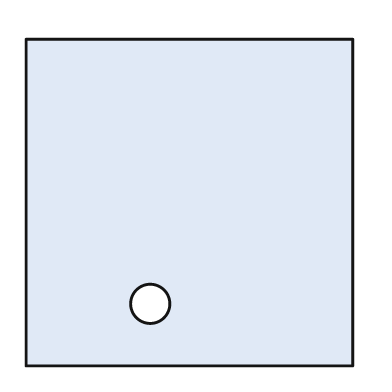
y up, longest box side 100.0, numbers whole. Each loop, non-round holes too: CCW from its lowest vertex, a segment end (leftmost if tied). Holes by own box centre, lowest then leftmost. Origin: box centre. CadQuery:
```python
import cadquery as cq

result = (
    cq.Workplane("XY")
    .moveTo(-50.0, -50.0)
    .lineTo(50.0, -50.0)
    .lineTo(50.0, 50.0)
    .lineTo(-50.0, 50.0)
    .close()
    .moveTo(-12.0, -31.0)
    .circle(6.0)
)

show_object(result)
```